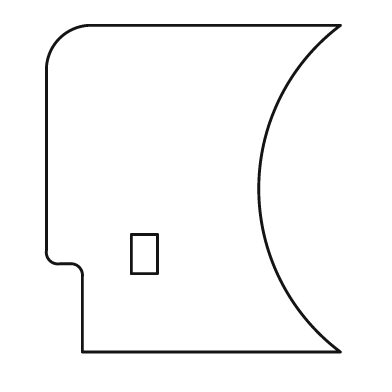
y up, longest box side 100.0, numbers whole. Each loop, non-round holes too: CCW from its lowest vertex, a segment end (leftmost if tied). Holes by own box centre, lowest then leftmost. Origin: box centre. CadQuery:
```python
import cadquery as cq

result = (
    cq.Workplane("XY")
    .moveTo(-34.0, -50.0)
    .lineTo(45.0, -50.0)
    .threePointArc((20.0, 0.0), (45.0, 50.0))
    .lineTo(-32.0, 50.0)
    .threePointArc((-41.0, 46.0), (-45.0, 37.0))
    .lineTo(-45.0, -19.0)
    .threePointArc((-44.0, -22.0), (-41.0, -23.0))
    .lineTo(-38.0, -23.0)
    .threePointArc((-35.0, -24.0), (-34.0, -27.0))
    .close()
    .moveTo(-19.0, -26.0)
    .lineTo(-11.0, -26.0)
    .lineTo(-11.0, -14.0)
    .lineTo(-19.0, -14.0)
    .close()
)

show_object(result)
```